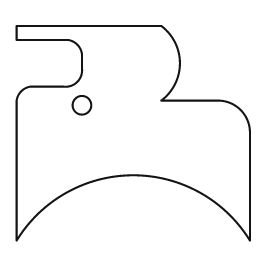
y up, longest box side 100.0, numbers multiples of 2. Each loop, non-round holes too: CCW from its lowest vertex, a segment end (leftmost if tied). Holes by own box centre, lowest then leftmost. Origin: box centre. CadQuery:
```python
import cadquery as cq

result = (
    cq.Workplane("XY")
    .moveTo(-50.0, -46.0)
    .threePointArc((0.0, -18.0), (50.0, -46.0))
    .lineTo(50.0, 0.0)
    .threePointArc((46.0, 10.0), (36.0, 14.0))
    .lineTo(12.0, 14.0)
    .threePointArc((20.0, 30.0), (12.0, 46.0))
    .lineTo(-50.0, 46.0)
    .lineTo(-50.0, 40.0)
    .lineTo(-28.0, 40.0)
    .threePointArc((-24.0, 38.0), (-22.0, 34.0))
    .lineTo(-22.0, 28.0)
    .threePointArc((-24.0, 22.0), (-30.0, 20.0))
    .lineTo(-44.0, 20.0)
    .threePointArc((-48.0, 18.0), (-50.0, 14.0))
    .close()
    .moveTo(-22.0, 12.0)
    .circle(4.0)
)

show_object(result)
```